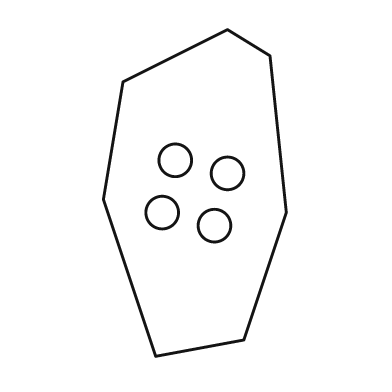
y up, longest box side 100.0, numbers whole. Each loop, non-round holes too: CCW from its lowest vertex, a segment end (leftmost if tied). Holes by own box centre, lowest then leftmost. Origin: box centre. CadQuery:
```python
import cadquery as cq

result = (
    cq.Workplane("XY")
    .moveTo(-12.0, -50.0)
    .lineTo(15.0, -45.0)
    .lineTo(28.0, -6.0)
    .lineTo(23.0, 42.0)
    .lineTo(10.0, 50.0)
    .lineTo(-22.0, 34.0)
    .lineTo(-28.0, -2.0)
    .close()
    .moveTo(6.0, -10.0)
    .circle(5.0)
    .moveTo(-10.0, -6.0)
    .circle(5.0)
    .moveTo(10.0, 6.0)
    .circle(5.0)
    .moveTo(-6.0, 10.0)
    .circle(5.0)
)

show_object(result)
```